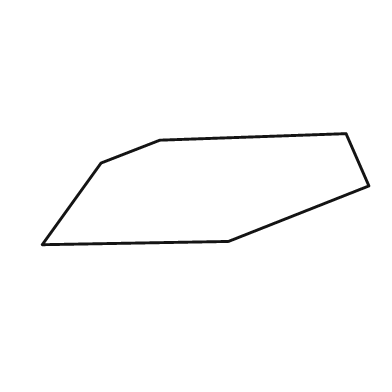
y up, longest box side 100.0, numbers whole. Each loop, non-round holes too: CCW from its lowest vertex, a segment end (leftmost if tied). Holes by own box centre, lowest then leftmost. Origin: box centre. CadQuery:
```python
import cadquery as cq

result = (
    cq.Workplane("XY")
    .moveTo(-50.0, -17.0)
    .lineTo(7.0, -16.0)
    .lineTo(50.0, 1.0)
    .lineTo(43.0, 17.0)
    .lineTo(-14.0, 15.0)
    .lineTo(-32.0, 8.0)
    .close()
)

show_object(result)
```